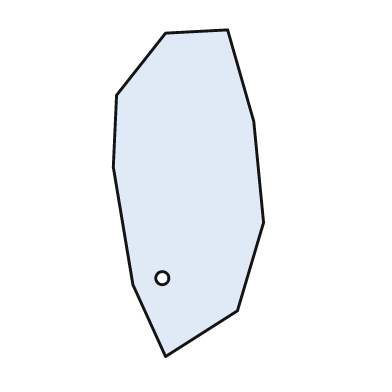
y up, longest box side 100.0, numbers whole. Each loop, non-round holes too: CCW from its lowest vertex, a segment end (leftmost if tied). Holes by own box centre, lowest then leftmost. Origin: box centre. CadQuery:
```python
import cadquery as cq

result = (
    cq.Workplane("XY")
    .moveTo(-7.0, -50.0)
    .lineTo(15.0, -36.0)
    .lineTo(23.0, -9.0)
    .lineTo(20.0, 22.0)
    .lineTo(12.0, 50.0)
    .lineTo(-7.0, 49.0)
    .lineTo(-22.0, 30.0)
    .lineTo(-23.0, 8.0)
    .lineTo(-17.0, -28.0)
    .close()
    .moveTo(-8.0, -26.0)
    .circle(2.0)
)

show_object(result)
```